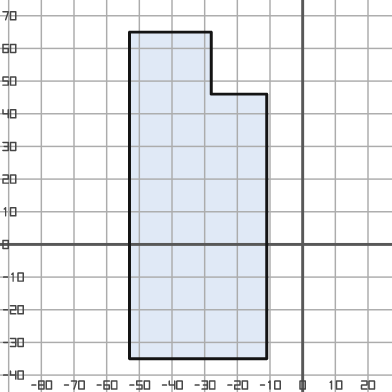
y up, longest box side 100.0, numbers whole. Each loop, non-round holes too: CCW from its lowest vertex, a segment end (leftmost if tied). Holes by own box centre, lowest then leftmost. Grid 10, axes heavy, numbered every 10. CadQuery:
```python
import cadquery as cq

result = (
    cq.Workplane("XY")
    .moveTo(-53.0, -35.0)
    .lineTo(-11.0, -35.0)
    .lineTo(-11.0, 46.0)
    .lineTo(-28.0, 46.0)
    .lineTo(-28.0, 65.0)
    .lineTo(-53.0, 65.0)
    .close()
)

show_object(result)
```